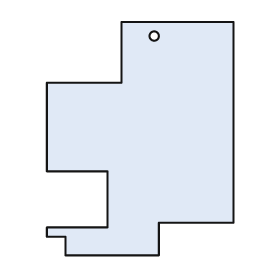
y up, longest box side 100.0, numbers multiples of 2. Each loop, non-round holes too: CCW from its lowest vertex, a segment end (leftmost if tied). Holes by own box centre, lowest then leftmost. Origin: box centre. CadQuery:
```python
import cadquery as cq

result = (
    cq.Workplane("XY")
    .moveTo(-32.0, -50.0)
    .lineTo(8.0, -50.0)
    .lineTo(8.0, -36.0)
    .lineTo(40.0, -36.0)
    .lineTo(40.0, 50.0)
    .lineTo(-8.0, 50.0)
    .lineTo(-8.0, 24.0)
    .lineTo(-40.0, 24.0)
    .lineTo(-40.0, -14.0)
    .lineTo(-14.0, -14.0)
    .lineTo(-14.0, -38.0)
    .lineTo(-40.0, -38.0)
    .lineTo(-40.0, -42.0)
    .lineTo(-32.0, -42.0)
    .close()
    .moveTo(6.0, 44.0)
    .circle(2.0)
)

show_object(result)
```